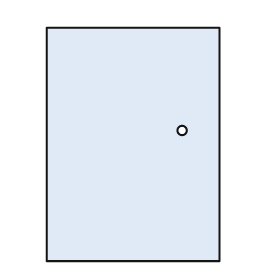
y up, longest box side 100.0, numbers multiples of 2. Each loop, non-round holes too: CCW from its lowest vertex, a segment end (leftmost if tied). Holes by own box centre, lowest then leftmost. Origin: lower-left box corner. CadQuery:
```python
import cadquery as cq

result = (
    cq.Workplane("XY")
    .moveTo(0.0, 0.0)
    .lineTo(74.0, 0.0)
    .lineTo(74.0, 100.0)
    .lineTo(0.0, 100.0)
    .close()
    .moveTo(58.0, 56.0)
    .circle(2.0)
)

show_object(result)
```